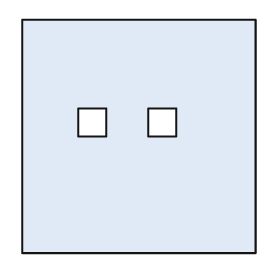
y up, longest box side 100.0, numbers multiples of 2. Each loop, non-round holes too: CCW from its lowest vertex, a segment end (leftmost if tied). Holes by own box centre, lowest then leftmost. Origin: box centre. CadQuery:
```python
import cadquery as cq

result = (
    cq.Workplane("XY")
    .moveTo(-50.0, -50.0)
    .lineTo(50.0, -50.0)
    .lineTo(50.0, 50.0)
    .lineTo(-50.0, 50.0)
    .close()
    .moveTo(-26.0, 0.0)
    .lineTo(-14.0, 0.0)
    .lineTo(-14.0, 12.0)
    .lineTo(-26.0, 12.0)
    .close()
    .moveTo(4.0, 0.0)
    .lineTo(16.0, 0.0)
    .lineTo(16.0, 12.0)
    .lineTo(4.0, 12.0)
    .close()
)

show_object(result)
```